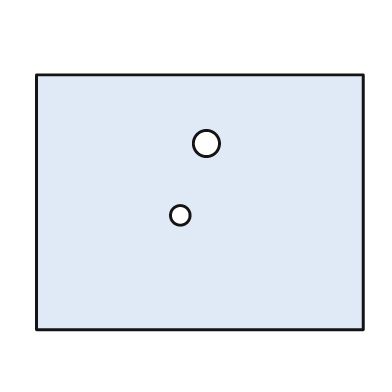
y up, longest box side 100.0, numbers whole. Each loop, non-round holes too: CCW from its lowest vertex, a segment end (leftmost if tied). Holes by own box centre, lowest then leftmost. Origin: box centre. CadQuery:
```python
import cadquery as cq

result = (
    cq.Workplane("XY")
    .moveTo(-50.0, -39.0)
    .lineTo(50.0, -39.0)
    .lineTo(50.0, 39.0)
    .lineTo(-50.0, 39.0)
    .close()
    .moveTo(-6.0, -4.0)
    .circle(3.0)
    .moveTo(2.0, 18.0)
    .circle(4.0)
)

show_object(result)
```